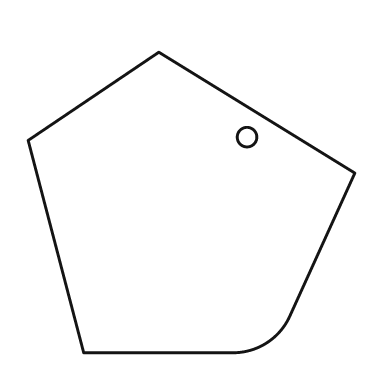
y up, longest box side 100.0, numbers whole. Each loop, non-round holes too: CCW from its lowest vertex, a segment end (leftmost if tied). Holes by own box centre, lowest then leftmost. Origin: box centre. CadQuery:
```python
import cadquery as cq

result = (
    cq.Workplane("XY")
    .moveTo(-33.0, -46.0)
    .lineTo(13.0, -46.0)
    .threePointArc((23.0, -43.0), (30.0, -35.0))
    .lineTo(50.0, 9.0)
    .lineTo(-10.0, 46.0)
    .lineTo(-50.0, 19.0)
    .close()
    .moveTo(17.0, 20.0)
    .circle(3.0)
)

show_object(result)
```